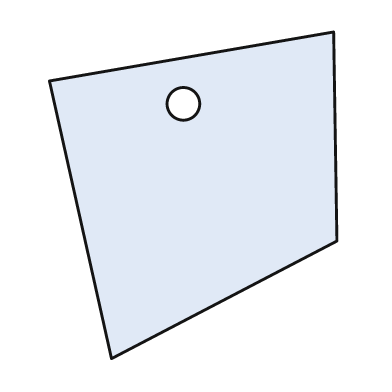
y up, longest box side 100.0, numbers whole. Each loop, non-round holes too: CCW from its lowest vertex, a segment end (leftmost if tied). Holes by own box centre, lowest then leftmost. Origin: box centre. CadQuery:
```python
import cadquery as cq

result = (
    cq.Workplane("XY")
    .moveTo(-25.0, -50.0)
    .lineTo(44.0, -14.0)
    .lineTo(43.0, 50.0)
    .lineTo(-44.0, 35.0)
    .close()
    .moveTo(-3.0, 28.0)
    .circle(5.0)
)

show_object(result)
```